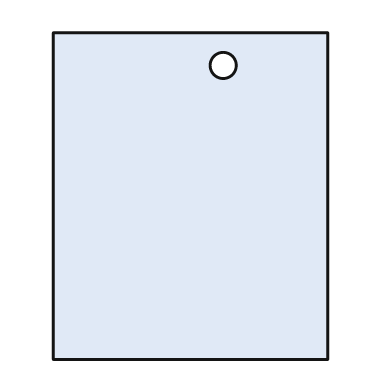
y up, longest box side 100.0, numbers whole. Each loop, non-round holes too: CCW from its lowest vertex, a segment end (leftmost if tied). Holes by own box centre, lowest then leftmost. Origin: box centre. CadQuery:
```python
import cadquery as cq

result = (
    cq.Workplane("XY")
    .moveTo(-42.0, -50.0)
    .lineTo(42.0, -50.0)
    .lineTo(42.0, 50.0)
    .lineTo(-42.0, 50.0)
    .close()
    .moveTo(10.0, 40.0)
    .circle(4.0)
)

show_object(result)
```